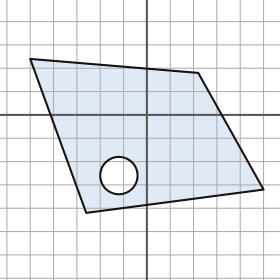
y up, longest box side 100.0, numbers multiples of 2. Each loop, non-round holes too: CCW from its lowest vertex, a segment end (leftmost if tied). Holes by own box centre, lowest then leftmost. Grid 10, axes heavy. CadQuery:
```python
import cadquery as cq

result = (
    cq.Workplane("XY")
    .moveTo(-26.0, -42.0)
    .lineTo(50.0, -32.0)
    .lineTo(22.0, 18.0)
    .lineTo(-50.0, 24.0)
    .close()
    .moveTo(-12.0, -26.0)
    .circle(8.0)
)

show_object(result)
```